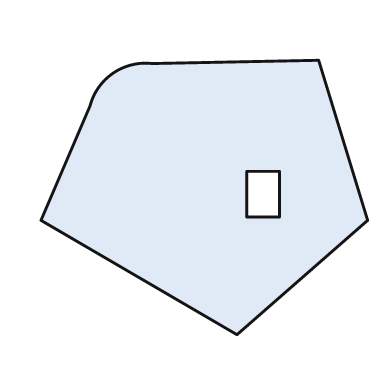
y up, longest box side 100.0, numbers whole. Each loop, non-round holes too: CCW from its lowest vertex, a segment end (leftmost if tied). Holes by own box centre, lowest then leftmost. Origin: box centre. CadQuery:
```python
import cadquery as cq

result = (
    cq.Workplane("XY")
    .moveTo(10.0, -42.0)
    .lineTo(50.0, -7.0)
    .lineTo(35.0, 42.0)
    .lineTo(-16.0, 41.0)
    .threePointArc((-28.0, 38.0), (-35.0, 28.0))
    .lineTo(-50.0, -7.0)
    .close()
    .moveTo(13.0, -6.0)
    .lineTo(23.0, -6.0)
    .lineTo(23.0, 8.0)
    .lineTo(13.0, 8.0)
    .close()
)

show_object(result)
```